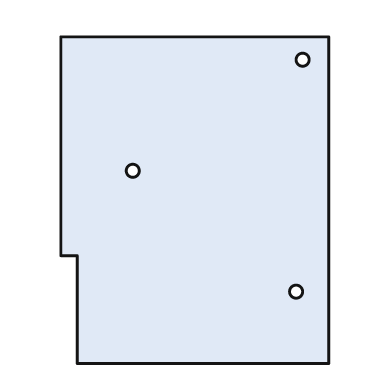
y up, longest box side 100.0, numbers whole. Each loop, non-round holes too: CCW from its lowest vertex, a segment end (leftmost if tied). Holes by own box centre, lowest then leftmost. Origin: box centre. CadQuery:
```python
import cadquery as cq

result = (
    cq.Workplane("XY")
    .moveTo(-36.0, -50.0)
    .lineTo(41.0, -50.0)
    .lineTo(41.0, 50.0)
    .lineTo(-41.0, 50.0)
    .lineTo(-41.0, -17.0)
    .lineTo(-36.0, -17.0)
    .close()
    .moveTo(31.0, -28.0)
    .circle(2.0)
    .moveTo(-19.0, 9.0)
    .circle(2.0)
    .moveTo(33.0, 43.0)
    .circle(2.0)
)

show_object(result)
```